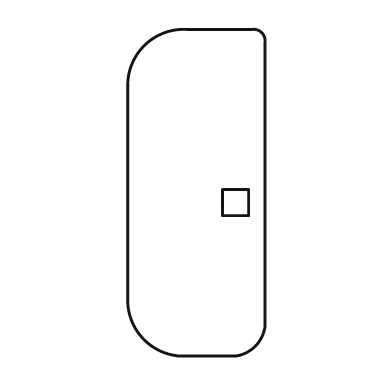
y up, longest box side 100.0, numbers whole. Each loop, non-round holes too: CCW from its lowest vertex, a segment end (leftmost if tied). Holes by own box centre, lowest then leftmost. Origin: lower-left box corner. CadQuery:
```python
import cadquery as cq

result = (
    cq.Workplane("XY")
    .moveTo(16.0, 0.0)
    .lineTo(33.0, 0.0)
    .threePointArc((39.0, 3.0), (42.0, 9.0))
    .lineTo(42.0, 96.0)
    .threePointArc((41.0, 99.0), (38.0, 100.0))
    .lineTo(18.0, 100.0)
    .threePointArc((5.0, 95.0), (0.0, 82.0))
    .lineTo(0.0, 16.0)
    .threePointArc((5.0, 5.0), (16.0, 0.0))
    .close()
    .moveTo(29.0, 43.0)
    .lineTo(37.0, 43.0)
    .lineTo(37.0, 51.0)
    .lineTo(29.0, 51.0)
    .close()
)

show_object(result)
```